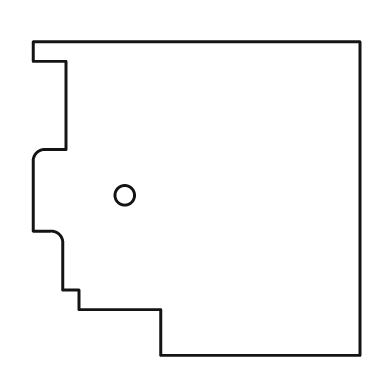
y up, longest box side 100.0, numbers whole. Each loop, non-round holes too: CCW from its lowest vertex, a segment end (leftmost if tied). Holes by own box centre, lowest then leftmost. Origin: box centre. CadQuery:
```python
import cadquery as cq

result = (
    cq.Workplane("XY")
    .moveTo(-11.0, -48.0)
    .lineTo(50.0, -48.0)
    .lineTo(50.0, 48.0)
    .lineTo(-50.0, 48.0)
    .lineTo(-50.0, 42.0)
    .lineTo(-40.0, 42.0)
    .lineTo(-40.0, 15.0)
    .lineTo(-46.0, 15.0)
    .threePointArc((-49.0, 14.0), (-50.0, 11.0))
    .lineTo(-50.0, -10.0)
    .lineTo(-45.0, -10.0)
    .threePointArc((-42.0, -11.0), (-41.0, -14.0))
    .lineTo(-41.0, -28.0)
    .lineTo(-36.0, -28.0)
    .lineTo(-36.0, -34.0)
    .lineTo(-11.0, -34.0)
    .close()
    .moveTo(-22.0, 1.0)
    .circle(3.0)
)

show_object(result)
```